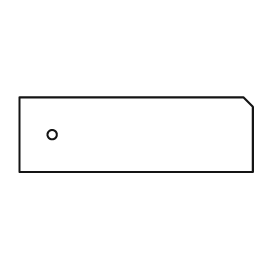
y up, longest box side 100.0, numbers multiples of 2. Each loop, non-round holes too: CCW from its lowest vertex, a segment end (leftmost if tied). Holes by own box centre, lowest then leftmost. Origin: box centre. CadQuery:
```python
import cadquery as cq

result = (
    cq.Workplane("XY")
    .moveTo(-50.0, -16.0)
    .lineTo(50.0, -16.0)
    .lineTo(50.0, 12.0)
    .lineTo(46.0, 16.0)
    .lineTo(-50.0, 16.0)
    .close()
    .moveTo(-36.0, 0.0)
    .circle(2.0)
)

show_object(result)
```